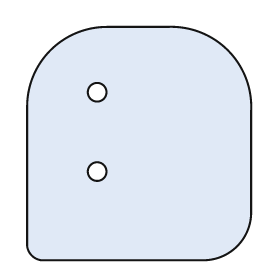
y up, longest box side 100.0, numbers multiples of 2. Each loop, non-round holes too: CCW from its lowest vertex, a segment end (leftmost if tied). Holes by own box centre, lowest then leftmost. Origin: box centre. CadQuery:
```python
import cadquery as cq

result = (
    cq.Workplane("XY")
    .moveTo(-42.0, -50.0)
    .lineTo(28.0, -50.0)
    .threePointArc((42.0, -44.0), (48.0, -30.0))
    .lineTo(48.0, 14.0)
    .threePointArc((38.0, 40.0), (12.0, 50.0))
    .lineTo(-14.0, 50.0)
    .threePointArc((-38.0, 40.0), (-48.0, 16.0))
    .lineTo(-48.0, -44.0)
    .threePointArc((-46.0, -48.0), (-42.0, -50.0))
    .close()
    .moveTo(-18.0, -12.0)
    .circle(4.0)
    .moveTo(-18.0, 22.0)
    .circle(4.0)
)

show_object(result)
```